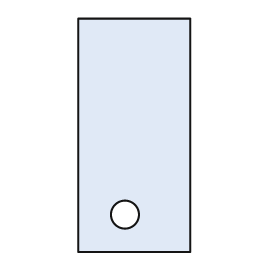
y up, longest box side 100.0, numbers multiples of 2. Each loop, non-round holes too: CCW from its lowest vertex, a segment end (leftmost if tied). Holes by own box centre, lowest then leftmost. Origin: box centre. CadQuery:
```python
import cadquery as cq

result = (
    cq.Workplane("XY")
    .moveTo(-24.0, -50.0)
    .lineTo(24.0, -50.0)
    .lineTo(24.0, 50.0)
    .lineTo(-24.0, 50.0)
    .close()
    .moveTo(-4.0, -34.0)
    .circle(6.0)
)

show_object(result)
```